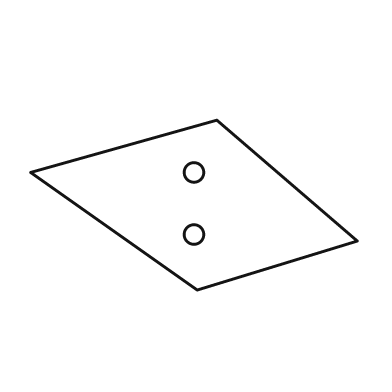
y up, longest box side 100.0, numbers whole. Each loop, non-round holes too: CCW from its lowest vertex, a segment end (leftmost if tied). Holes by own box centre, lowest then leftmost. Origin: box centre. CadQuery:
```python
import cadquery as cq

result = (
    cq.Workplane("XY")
    .moveTo(1.0, -26.0)
    .lineTo(50.0, -11.0)
    .lineTo(7.0, 26.0)
    .lineTo(-50.0, 10.0)
    .close()
    .moveTo(0.0, -9.0)
    .circle(3.0)
    .moveTo(0.0, 10.0)
    .circle(3.0)
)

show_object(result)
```